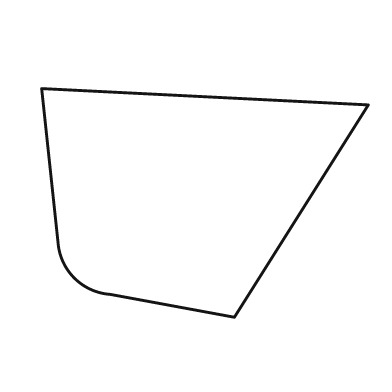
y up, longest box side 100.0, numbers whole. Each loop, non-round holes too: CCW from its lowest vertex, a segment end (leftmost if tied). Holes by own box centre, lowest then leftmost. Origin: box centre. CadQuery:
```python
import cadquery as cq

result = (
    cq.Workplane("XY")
    .moveTo(9.0, -35.0)
    .lineTo(50.0, 30.0)
    .lineTo(-50.0, 35.0)
    .lineTo(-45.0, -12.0)
    .threePointArc((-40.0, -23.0), (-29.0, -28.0))
    .close()
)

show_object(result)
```